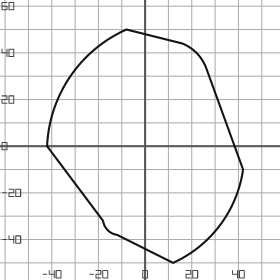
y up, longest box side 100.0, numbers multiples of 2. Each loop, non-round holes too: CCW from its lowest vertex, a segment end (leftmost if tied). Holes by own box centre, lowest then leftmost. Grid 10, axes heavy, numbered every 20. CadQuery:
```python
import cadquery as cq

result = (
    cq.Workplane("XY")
    .moveTo(12.0, -50.0)
    .threePointArc((32.0, -34.0), (42.0, -10.0))
    .lineTo(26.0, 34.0)
    .threePointArc((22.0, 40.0), (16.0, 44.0))
    .lineTo(-8.0, 50.0)
    .threePointArc((-32.0, 30.0), (-42.0, 0.0))
    .lineTo(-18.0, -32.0)
    .threePointArc((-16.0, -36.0), (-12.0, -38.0))
    .close()
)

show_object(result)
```